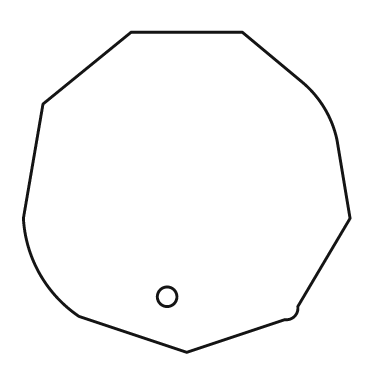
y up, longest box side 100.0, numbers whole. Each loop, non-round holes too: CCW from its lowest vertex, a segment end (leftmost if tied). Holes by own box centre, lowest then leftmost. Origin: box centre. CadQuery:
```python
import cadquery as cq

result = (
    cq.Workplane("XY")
    .moveTo(0.0, -49.0)
    .lineTo(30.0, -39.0)
    .threePointArc((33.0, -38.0), (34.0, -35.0))
    .lineTo(50.0, -8.0)
    .lineTo(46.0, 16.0)
    .threePointArc((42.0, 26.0), (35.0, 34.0))
    .lineTo(17.0, 49.0)
    .lineTo(-17.0, 49.0)
    .lineTo(-44.0, 27.0)
    .lineTo(-50.0, -8.0)
    .threePointArc((-45.0, -25.0), (-33.0, -38.0))
    .close()
    .moveTo(-6.0, -32.0)
    .circle(3.0)
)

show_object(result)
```